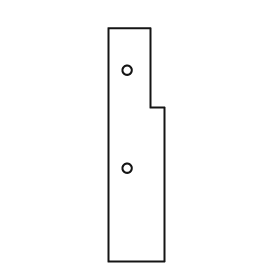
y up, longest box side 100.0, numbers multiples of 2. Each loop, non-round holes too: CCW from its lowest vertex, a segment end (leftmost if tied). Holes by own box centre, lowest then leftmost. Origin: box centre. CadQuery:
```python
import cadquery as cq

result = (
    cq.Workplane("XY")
    .moveTo(-12.0, -50.0)
    .lineTo(12.0, -50.0)
    .lineTo(12.0, 16.0)
    .lineTo(6.0, 16.0)
    .lineTo(6.0, 50.0)
    .lineTo(-12.0, 50.0)
    .close()
    .moveTo(-4.0, -10.0)
    .circle(2.0)
    .moveTo(-4.0, 32.0)
    .circle(2.0)
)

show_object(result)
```